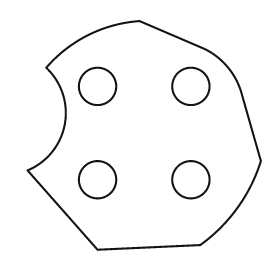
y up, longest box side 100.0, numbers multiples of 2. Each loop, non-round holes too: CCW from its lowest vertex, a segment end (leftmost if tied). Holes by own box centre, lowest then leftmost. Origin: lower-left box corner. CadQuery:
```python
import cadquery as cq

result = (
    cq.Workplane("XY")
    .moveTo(30.0, 0.0)
    .lineTo(74.0, 2.0)
    .threePointArc((90.0, 18.0), (100.0, 38.0))
    .lineTo(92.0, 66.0)
    .threePointArc((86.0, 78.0), (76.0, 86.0))
    .lineTo(48.0, 98.0)
    .threePointArc((26.0, 92.0), (8.0, 78.0))
    .threePointArc((16.0, 54.0), (0.0, 34.0))
    .close()
    .moveTo(30.0, 30.0)
    .circle(8.0)
    .moveTo(70.0, 30.0)
    .circle(8.0)
    .moveTo(30.0, 70.0)
    .circle(8.0)
    .moveTo(70.0, 70.0)
    .circle(8.0)
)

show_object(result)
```